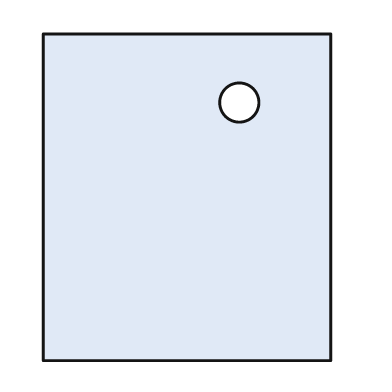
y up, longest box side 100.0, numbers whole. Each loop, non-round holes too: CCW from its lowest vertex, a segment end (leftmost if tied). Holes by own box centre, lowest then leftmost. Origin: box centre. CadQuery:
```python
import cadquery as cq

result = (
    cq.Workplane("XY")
    .moveTo(-44.0, -50.0)
    .lineTo(44.0, -50.0)
    .lineTo(44.0, 50.0)
    .lineTo(-44.0, 50.0)
    .close()
    .moveTo(16.0, 29.0)
    .circle(6.0)
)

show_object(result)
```